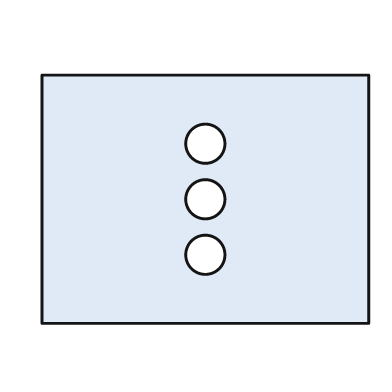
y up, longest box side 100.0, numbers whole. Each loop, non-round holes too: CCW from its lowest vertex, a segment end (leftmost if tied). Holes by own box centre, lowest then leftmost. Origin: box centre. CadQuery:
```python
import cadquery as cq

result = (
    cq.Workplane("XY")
    .moveTo(-50.0, -38.0)
    .lineTo(50.0, -38.0)
    .lineTo(50.0, 38.0)
    .lineTo(-50.0, 38.0)
    .close()
    .moveTo(0.0, -17.0)
    .circle(6.0)
    .moveTo(0.0, 0.0)
    .circle(6.0)
    .moveTo(0.0, 17.0)
    .circle(6.0)
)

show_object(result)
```